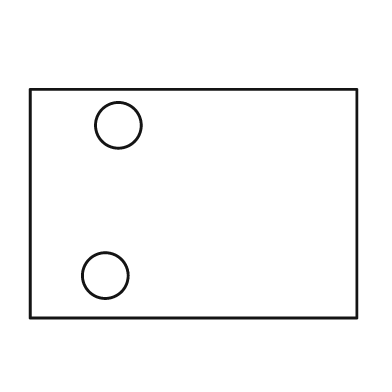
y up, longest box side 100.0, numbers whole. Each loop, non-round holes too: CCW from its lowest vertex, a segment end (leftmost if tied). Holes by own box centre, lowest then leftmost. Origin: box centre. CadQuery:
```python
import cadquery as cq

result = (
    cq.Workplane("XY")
    .moveTo(-50.0, -35.0)
    .lineTo(50.0, -35.0)
    .lineTo(50.0, 35.0)
    .lineTo(-50.0, 35.0)
    .close()
    .moveTo(-27.0, -22.0)
    .circle(7.0)
    .moveTo(-23.0, 24.0)
    .circle(7.0)
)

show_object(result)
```